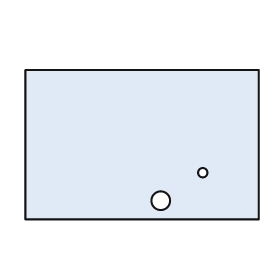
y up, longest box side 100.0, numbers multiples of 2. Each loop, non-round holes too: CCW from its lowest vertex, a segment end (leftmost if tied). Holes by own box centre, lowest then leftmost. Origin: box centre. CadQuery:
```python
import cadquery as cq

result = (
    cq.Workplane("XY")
    .moveTo(-50.0, -32.0)
    .lineTo(50.0, -32.0)
    .lineTo(50.0, 32.0)
    .lineTo(-50.0, 32.0)
    .close()
    .moveTo(8.0, -24.0)
    .circle(4.0)
    .moveTo(26.0, -12.0)
    .circle(2.0)
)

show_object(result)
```